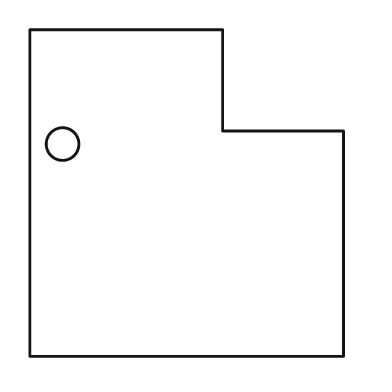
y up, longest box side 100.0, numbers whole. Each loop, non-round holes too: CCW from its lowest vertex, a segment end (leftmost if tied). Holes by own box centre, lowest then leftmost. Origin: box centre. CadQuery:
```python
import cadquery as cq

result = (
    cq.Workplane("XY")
    .moveTo(-48.0, -50.0)
    .lineTo(48.0, -50.0)
    .lineTo(48.0, 19.0)
    .lineTo(11.0, 19.0)
    .lineTo(11.0, 50.0)
    .lineTo(-48.0, 50.0)
    .close()
    .moveTo(-38.0, 15.0)
    .circle(5.0)
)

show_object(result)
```